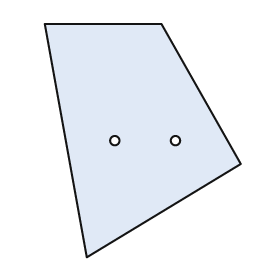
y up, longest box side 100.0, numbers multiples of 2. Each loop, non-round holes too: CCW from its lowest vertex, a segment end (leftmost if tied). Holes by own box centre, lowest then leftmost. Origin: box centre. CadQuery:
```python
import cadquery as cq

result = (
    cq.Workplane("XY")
    .moveTo(-24.0, -50.0)
    .lineTo(42.0, -10.0)
    .lineTo(8.0, 50.0)
    .lineTo(-42.0, 50.0)
    .close()
    .moveTo(-12.0, 0.0)
    .circle(2.0)
    .moveTo(14.0, 0.0)
    .circle(2.0)
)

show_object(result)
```